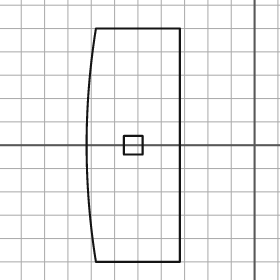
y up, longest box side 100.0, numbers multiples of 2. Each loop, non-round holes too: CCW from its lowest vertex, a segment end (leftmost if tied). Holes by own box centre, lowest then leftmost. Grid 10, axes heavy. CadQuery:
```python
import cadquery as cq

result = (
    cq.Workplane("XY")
    .moveTo(-68.0, -50.0)
    .lineTo(-32.0, -50.0)
    .lineTo(-32.0, 50.0)
    .lineTo(-68.0, 50.0)
    .threePointArc((-72.0, 0.0), (-68.0, -50.0))
    .close()
    .moveTo(-56.0, -4.0)
    .lineTo(-48.0, -4.0)
    .lineTo(-48.0, 4.0)
    .lineTo(-56.0, 4.0)
    .close()
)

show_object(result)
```